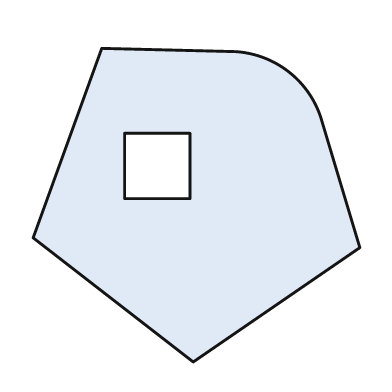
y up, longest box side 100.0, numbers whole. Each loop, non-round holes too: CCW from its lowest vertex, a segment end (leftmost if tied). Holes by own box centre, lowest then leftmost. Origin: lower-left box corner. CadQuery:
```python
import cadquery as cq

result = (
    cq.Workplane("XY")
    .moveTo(49.0, 0.0)
    .lineTo(100.0, 35.0)
    .lineTo(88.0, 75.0)
    .threePointArc((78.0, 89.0), (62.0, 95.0))
    .lineTo(21.0, 96.0)
    .lineTo(0.0, 38.0)
    .close()
    .moveTo(28.0, 50.0)
    .lineTo(48.0, 50.0)
    .lineTo(48.0, 70.0)
    .lineTo(28.0, 70.0)
    .close()
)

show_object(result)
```